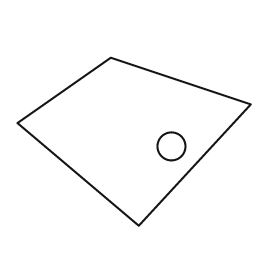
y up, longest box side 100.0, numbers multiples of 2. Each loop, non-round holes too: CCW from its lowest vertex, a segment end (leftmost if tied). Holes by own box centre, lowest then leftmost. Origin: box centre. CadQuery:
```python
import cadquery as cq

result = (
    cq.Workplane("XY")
    .moveTo(2.0, -36.0)
    .lineTo(50.0, 16.0)
    .lineTo(-10.0, 36.0)
    .lineTo(-50.0, 8.0)
    .close()
    .moveTo(16.0, -2.0)
    .circle(6.0)
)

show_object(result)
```